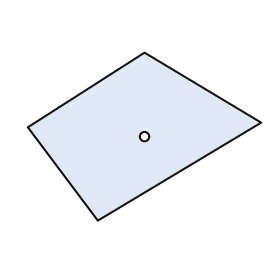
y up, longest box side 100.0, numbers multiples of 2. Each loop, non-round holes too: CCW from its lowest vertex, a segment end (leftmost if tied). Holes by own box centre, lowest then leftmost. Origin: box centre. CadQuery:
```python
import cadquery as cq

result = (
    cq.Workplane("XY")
    .moveTo(-20.0, -36.0)
    .lineTo(50.0, 6.0)
    .lineTo(0.0, 36.0)
    .lineTo(-50.0, 4.0)
    .close()
    .moveTo(0.0, 0.0)
    .circle(2.0)
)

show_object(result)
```